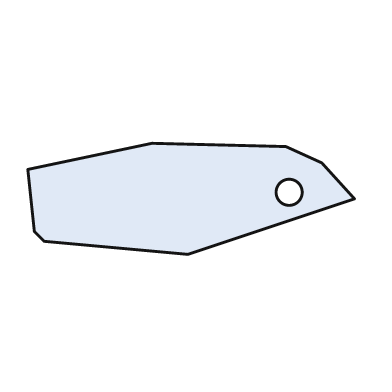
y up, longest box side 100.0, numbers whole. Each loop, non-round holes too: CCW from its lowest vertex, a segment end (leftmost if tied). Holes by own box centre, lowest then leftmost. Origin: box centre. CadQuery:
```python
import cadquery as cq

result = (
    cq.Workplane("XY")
    .moveTo(-1.0, -17.0)
    .lineTo(50.0, 0.0)
    .lineTo(40.0, 11.0)
    .lineTo(29.0, 16.0)
    .lineTo(-12.0, 17.0)
    .lineTo(-50.0, 9.0)
    .lineTo(-48.0, -10.0)
    .lineTo(-45.0, -13.0)
    .close()
    .moveTo(30.0, 2.0)
    .circle(4.0)
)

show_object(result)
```